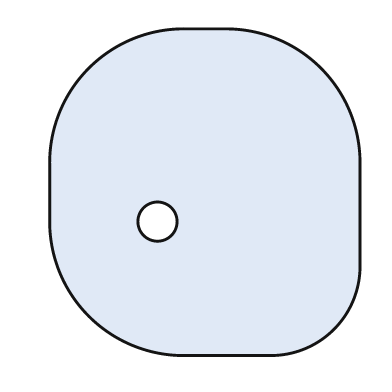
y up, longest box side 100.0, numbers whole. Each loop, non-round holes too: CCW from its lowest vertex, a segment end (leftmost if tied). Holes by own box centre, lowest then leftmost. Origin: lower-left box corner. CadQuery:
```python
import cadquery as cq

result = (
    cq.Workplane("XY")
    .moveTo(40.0, 0.0)
    .lineTo(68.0, 0.0)
    .threePointArc((87.0, 8.0), (95.0, 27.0))
    .lineTo(95.0, 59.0)
    .threePointArc((83.0, 88.0), (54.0, 100.0))
    .lineTo(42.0, 100.0)
    .threePointArc((12.0, 88.0), (0.0, 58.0))
    .lineTo(0.0, 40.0)
    .threePointArc((12.0, 12.0), (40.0, 0.0))
    .close()
    .moveTo(33.0, 41.0)
    .circle(6.0)
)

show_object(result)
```